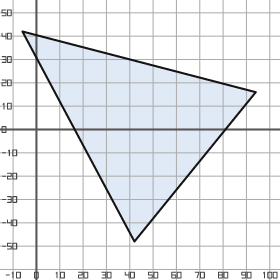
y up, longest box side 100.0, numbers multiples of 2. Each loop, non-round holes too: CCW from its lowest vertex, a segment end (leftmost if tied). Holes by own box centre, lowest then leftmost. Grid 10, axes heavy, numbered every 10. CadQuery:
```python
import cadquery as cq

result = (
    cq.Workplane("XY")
    .moveTo(42.0, -48.0)
    .lineTo(94.0, 16.0)
    .lineTo(-6.0, 42.0)
    .close()
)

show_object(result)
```